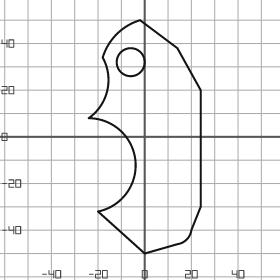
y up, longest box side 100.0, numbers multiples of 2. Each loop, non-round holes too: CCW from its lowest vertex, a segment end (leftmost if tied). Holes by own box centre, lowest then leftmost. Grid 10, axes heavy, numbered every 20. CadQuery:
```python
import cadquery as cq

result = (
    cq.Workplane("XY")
    .moveTo(0.0, -50.0)
    .lineTo(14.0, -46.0)
    .threePointArc((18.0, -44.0), (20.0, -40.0))
    .lineTo(24.0, -30.0)
    .lineTo(24.0, 20.0)
    .lineTo(14.0, 38.0)
    .lineTo(-2.0, 50.0)
    .threePointArc((-12.0, 44.0), (-18.0, 34.0))
    .threePointArc((-16.0, 20.0), (-24.0, 8.0))
    .threePointArc((-4.0, -10.0), (-20.0, -32.0))
    .close()
    .moveTo(-6.0, 32.0)
    .circle(6.0)
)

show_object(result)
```